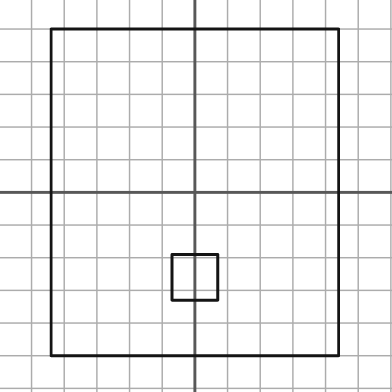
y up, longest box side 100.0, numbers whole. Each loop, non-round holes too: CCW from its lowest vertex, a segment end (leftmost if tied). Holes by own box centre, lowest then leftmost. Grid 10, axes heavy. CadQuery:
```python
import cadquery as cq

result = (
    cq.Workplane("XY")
    .moveTo(-44.0, -50.0)
    .lineTo(44.0, -50.0)
    .lineTo(44.0, 50.0)
    .lineTo(-44.0, 50.0)
    .close()
    .moveTo(-7.0, -33.0)
    .lineTo(7.0, -33.0)
    .lineTo(7.0, -19.0)
    .lineTo(-7.0, -19.0)
    .close()
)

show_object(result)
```